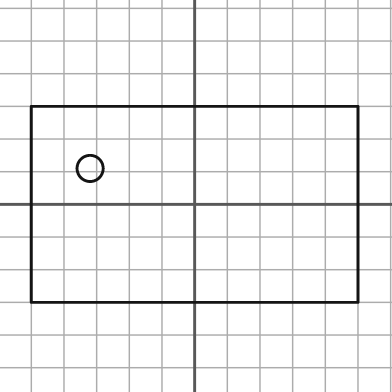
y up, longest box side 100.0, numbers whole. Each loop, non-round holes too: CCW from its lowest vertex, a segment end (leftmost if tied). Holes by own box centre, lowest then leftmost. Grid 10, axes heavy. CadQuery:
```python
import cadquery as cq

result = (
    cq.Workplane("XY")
    .moveTo(-50.0, -30.0)
    .lineTo(50.0, -30.0)
    .lineTo(50.0, 30.0)
    .lineTo(-50.0, 30.0)
    .close()
    .moveTo(-32.0, 11.0)
    .circle(4.0)
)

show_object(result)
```